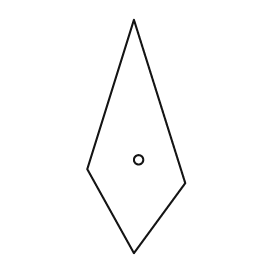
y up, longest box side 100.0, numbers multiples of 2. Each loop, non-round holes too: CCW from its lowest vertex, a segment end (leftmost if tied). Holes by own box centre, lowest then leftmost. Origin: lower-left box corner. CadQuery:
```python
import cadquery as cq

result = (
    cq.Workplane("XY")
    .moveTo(20.0, 0.0)
    .lineTo(42.0, 30.0)
    .lineTo(20.0, 100.0)
    .lineTo(0.0, 36.0)
    .close()
    .moveTo(22.0, 40.0)
    .circle(2.0)
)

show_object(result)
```